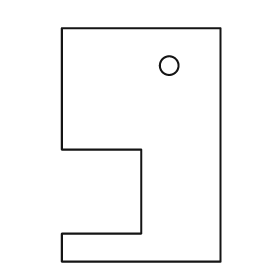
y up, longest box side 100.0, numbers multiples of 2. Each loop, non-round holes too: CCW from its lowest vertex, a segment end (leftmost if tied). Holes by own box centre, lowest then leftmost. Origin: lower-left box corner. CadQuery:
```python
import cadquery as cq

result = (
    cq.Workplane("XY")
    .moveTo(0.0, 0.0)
    .lineTo(68.0, 0.0)
    .lineTo(68.0, 100.0)
    .lineTo(0.0, 100.0)
    .lineTo(0.0, 48.0)
    .lineTo(34.0, 48.0)
    .lineTo(34.0, 12.0)
    .lineTo(0.0, 12.0)
    .close()
    .moveTo(46.0, 84.0)
    .circle(4.0)
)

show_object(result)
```